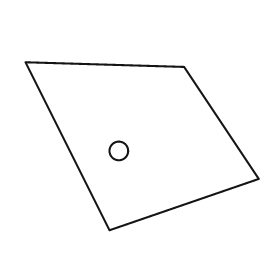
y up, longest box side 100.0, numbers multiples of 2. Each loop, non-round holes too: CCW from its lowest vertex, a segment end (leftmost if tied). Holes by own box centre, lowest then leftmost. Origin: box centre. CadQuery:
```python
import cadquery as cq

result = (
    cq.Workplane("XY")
    .moveTo(-14.0, -36.0)
    .lineTo(50.0, -14.0)
    .lineTo(18.0, 34.0)
    .lineTo(-50.0, 36.0)
    .close()
    .moveTo(-10.0, -2.0)
    .circle(4.0)
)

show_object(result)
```